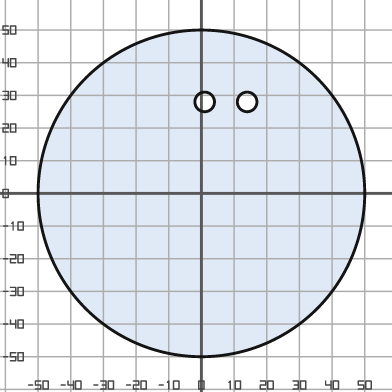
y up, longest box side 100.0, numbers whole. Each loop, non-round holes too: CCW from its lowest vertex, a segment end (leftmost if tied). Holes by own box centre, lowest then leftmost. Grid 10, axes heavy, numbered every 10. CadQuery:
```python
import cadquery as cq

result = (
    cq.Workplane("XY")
    .moveTo(0.0, 0.0)
    .circle(50.0)
    .moveTo(1.0, 28.0)
    .circle(3.0)
    .moveTo(14.0, 28.0)
    .circle(3.0)
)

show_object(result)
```